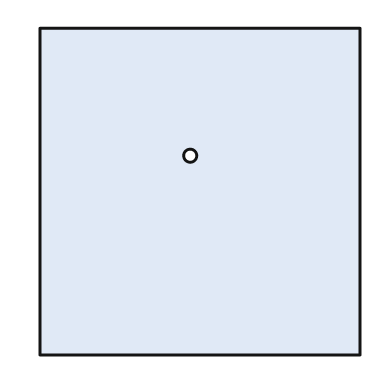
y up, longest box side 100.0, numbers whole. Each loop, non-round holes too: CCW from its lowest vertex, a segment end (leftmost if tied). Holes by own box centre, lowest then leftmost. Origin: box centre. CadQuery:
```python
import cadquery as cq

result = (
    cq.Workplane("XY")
    .moveTo(-49.0, -50.0)
    .lineTo(49.0, -50.0)
    .lineTo(49.0, 50.0)
    .lineTo(-49.0, 50.0)
    .close()
    .moveTo(-3.0, 11.0)
    .circle(2.0)
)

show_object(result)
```